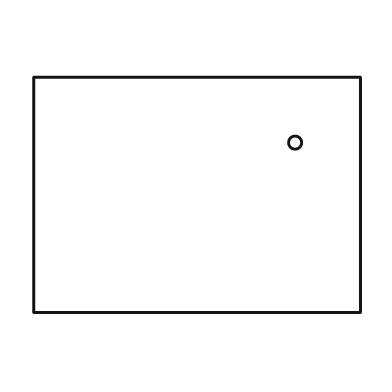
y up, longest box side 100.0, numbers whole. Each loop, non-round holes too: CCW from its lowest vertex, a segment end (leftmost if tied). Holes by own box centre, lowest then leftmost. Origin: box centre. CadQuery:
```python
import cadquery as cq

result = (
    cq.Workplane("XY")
    .moveTo(-50.0, -36.0)
    .lineTo(50.0, -36.0)
    .lineTo(50.0, 36.0)
    .lineTo(-50.0, 36.0)
    .close()
    .moveTo(30.0, 16.0)
    .circle(2.0)
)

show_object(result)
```